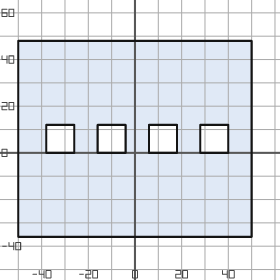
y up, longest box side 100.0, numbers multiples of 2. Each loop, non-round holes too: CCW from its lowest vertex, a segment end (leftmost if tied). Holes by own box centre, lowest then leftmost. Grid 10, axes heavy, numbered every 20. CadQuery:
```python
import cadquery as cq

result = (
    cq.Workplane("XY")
    .moveTo(-50.0, -36.0)
    .lineTo(50.0, -36.0)
    .lineTo(50.0, 48.0)
    .lineTo(-50.0, 48.0)
    .close()
    .moveTo(-38.0, 0.0)
    .lineTo(-26.0, 0.0)
    .lineTo(-26.0, 12.0)
    .lineTo(-38.0, 12.0)
    .close()
    .moveTo(-16.0, 0.0)
    .lineTo(-4.0, 0.0)
    .lineTo(-4.0, 12.0)
    .lineTo(-16.0, 12.0)
    .close()
    .moveTo(6.0, 0.0)
    .lineTo(18.0, 0.0)
    .lineTo(18.0, 12.0)
    .lineTo(6.0, 12.0)
    .close()
    .moveTo(28.0, 0.0)
    .lineTo(40.0, 0.0)
    .lineTo(40.0, 12.0)
    .lineTo(28.0, 12.0)
    .close()
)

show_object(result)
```